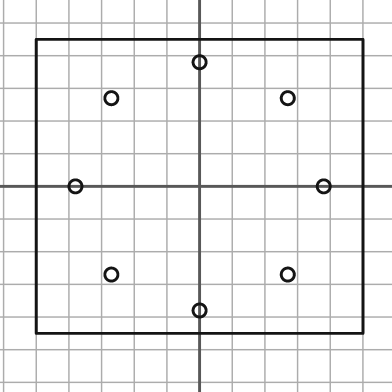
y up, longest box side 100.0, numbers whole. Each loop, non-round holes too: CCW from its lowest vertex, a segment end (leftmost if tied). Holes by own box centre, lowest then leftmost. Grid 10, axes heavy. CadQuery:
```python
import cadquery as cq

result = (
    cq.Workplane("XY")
    .moveTo(-50.0, -45.0)
    .lineTo(50.0, -45.0)
    .lineTo(50.0, 45.0)
    .lineTo(-50.0, 45.0)
    .close()
    .moveTo(0.0, -38.0)
    .circle(2.0)
    .moveTo(-27.0, -27.0)
    .circle(2.0)
    .moveTo(27.0, -27.0)
    .circle(2.0)
    .moveTo(-38.0, 0.0)
    .circle(2.0)
    .moveTo(38.0, 0.0)
    .circle(2.0)
    .moveTo(-27.0, 27.0)
    .circle(2.0)
    .moveTo(27.0, 27.0)
    .circle(2.0)
    .moveTo(0.0, 38.0)
    .circle(2.0)
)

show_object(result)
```